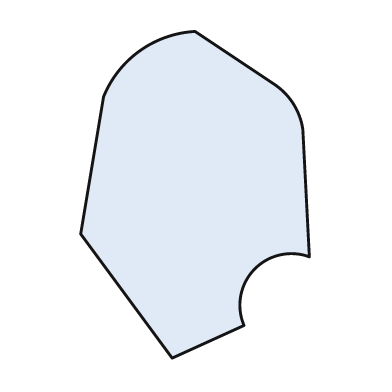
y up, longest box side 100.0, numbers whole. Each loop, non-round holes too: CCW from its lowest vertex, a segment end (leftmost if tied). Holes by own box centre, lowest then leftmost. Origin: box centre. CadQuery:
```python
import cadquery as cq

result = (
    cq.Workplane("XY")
    .moveTo(-7.0, -50.0)
    .lineTo(15.0, -40.0)
    .threePointArc((18.0, -23.0), (35.0, -19.0))
    .lineTo(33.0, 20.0)
    .threePointArc((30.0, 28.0), (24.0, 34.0))
    .lineTo(0.0, 50.0)
    .threePointArc((-17.0, 44.0), (-28.0, 30.0))
    .lineTo(-35.0, -12.0)
    .close()
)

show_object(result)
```